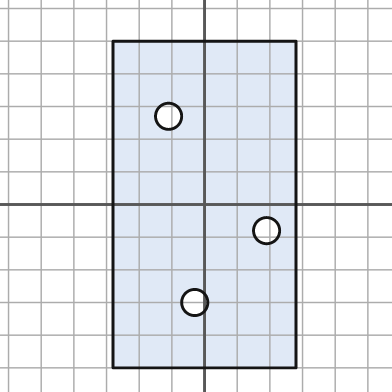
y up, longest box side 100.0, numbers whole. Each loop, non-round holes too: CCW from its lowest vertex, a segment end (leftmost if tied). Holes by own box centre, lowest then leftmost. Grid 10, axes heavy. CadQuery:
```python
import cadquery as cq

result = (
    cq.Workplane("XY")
    .moveTo(-28.0, -50.0)
    .lineTo(28.0, -50.0)
    .lineTo(28.0, 50.0)
    .lineTo(-28.0, 50.0)
    .close()
    .moveTo(-3.0, -30.0)
    .circle(4.0)
    .moveTo(19.0, -8.0)
    .circle(4.0)
    .moveTo(-11.0, 27.0)
    .circle(4.0)
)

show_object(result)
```